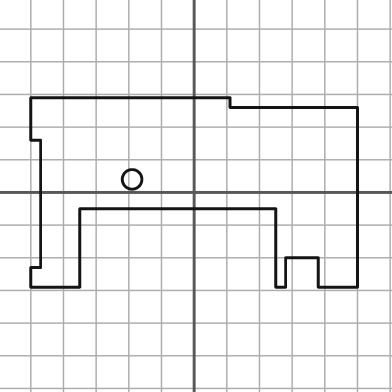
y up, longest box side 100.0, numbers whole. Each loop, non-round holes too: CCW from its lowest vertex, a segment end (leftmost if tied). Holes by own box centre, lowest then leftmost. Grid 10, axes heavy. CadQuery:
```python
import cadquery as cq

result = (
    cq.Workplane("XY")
    .moveTo(-50.0, -29.0)
    .lineTo(-35.0, -29.0)
    .lineTo(-35.0, -5.0)
    .lineTo(25.0, -5.0)
    .lineTo(25.0, -29.0)
    .lineTo(28.0, -29.0)
    .lineTo(28.0, -20.0)
    .lineTo(38.0, -20.0)
    .lineTo(38.0, -29.0)
    .lineTo(50.0, -29.0)
    .lineTo(50.0, 26.0)
    .lineTo(11.0, 26.0)
    .lineTo(11.0, 29.0)
    .lineTo(-50.0, 29.0)
    .lineTo(-50.0, 16.0)
    .lineTo(-47.0, 16.0)
    .lineTo(-47.0, -23.0)
    .lineTo(-50.0, -23.0)
    .close()
    .moveTo(-19.0, 4.0)
    .circle(3.0)
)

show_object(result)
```